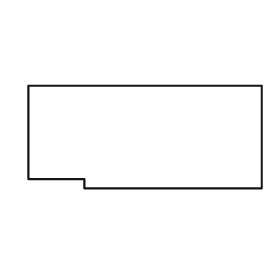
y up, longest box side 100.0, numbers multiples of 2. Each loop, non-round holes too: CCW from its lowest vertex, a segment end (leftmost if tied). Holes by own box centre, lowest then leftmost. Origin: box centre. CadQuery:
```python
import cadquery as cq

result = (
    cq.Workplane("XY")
    .moveTo(-26.0, -22.0)
    .lineTo(50.0, -22.0)
    .lineTo(50.0, 22.0)
    .lineTo(-50.0, 22.0)
    .lineTo(-50.0, -18.0)
    .lineTo(-26.0, -18.0)
    .close()
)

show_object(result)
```